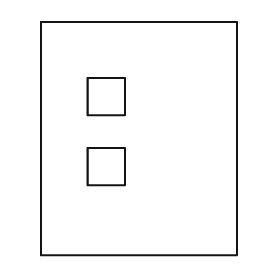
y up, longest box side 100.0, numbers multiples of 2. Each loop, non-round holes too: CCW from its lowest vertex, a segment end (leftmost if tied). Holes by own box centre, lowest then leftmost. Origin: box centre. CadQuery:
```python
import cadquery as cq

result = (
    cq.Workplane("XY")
    .moveTo(-42.0, -50.0)
    .lineTo(42.0, -50.0)
    .lineTo(42.0, 50.0)
    .lineTo(-42.0, 50.0)
    .close()
    .moveTo(-22.0, -20.0)
    .lineTo(-6.0, -20.0)
    .lineTo(-6.0, -4.0)
    .lineTo(-22.0, -4.0)
    .close()
    .moveTo(-22.0, 10.0)
    .lineTo(-6.0, 10.0)
    .lineTo(-6.0, 26.0)
    .lineTo(-22.0, 26.0)
    .close()
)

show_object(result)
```